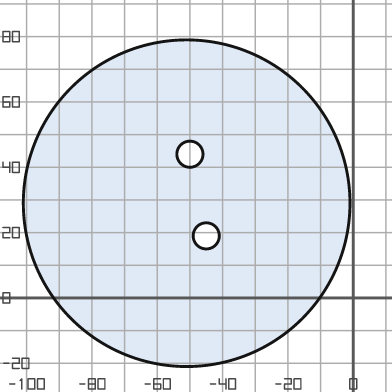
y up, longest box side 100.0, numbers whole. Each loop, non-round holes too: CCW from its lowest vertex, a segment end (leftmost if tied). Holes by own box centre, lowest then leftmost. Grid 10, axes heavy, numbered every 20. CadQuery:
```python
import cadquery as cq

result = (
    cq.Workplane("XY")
    .moveTo(-51.0, 29.0)
    .circle(50.0)
    .moveTo(-45.0, 19.0)
    .circle(4.0)
    .moveTo(-50.0, 44.0)
    .circle(4.0)
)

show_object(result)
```